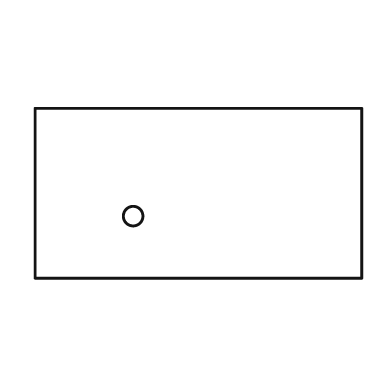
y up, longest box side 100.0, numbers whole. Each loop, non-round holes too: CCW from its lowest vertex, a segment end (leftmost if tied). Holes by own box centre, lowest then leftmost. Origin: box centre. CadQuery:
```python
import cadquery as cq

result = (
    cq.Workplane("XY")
    .moveTo(-50.0, -26.0)
    .lineTo(50.0, -26.0)
    .lineTo(50.0, 26.0)
    .lineTo(-50.0, 26.0)
    .close()
    .moveTo(-20.0, -7.0)
    .circle(3.0)
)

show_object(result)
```